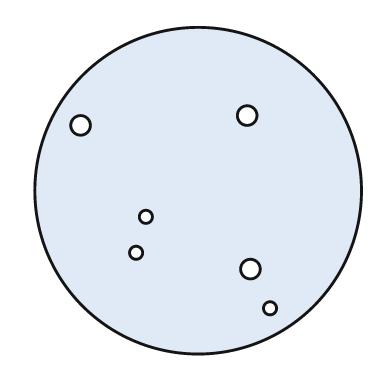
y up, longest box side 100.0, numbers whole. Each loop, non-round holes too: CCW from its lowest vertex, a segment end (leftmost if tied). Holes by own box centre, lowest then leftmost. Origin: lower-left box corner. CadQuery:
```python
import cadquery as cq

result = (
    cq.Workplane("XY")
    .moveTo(50.0, 50.0)
    .circle(50.0)
    .moveTo(72.0, 14.0)
    .circle(2.0)
    .moveTo(66.0, 26.0)
    .circle(3.0)
    .moveTo(31.0, 31.0)
    .circle(2.0)
    .moveTo(34.0, 42.0)
    .circle(2.0)
    .moveTo(14.0, 70.0)
    .circle(3.0)
    .moveTo(65.0, 73.0)
    .circle(3.0)
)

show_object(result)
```